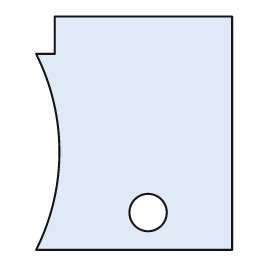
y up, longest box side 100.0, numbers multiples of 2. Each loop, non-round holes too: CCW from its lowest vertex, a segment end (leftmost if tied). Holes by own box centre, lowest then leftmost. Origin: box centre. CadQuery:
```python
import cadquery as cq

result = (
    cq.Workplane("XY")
    .moveTo(-42.0, -50.0)
    .lineTo(42.0, -50.0)
    .lineTo(42.0, 50.0)
    .lineTo(-34.0, 50.0)
    .lineTo(-34.0, 34.0)
    .lineTo(-42.0, 34.0)
    .threePointArc((-32.0, -8.0), (-42.0, -50.0))
    .close()
    .moveTo(6.0, -34.0)
    .circle(8.0)
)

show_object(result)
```